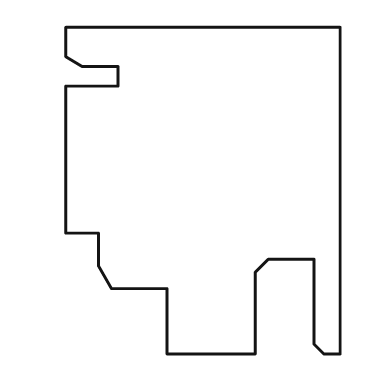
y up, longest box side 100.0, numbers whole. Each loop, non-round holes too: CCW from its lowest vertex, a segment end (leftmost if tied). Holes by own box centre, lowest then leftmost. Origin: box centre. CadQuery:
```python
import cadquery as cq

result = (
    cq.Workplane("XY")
    .moveTo(-11.0, -50.0)
    .lineTo(16.0, -50.0)
    .lineTo(16.0, -25.0)
    .lineTo(20.0, -21.0)
    .lineTo(34.0, -21.0)
    .lineTo(34.0, -47.0)
    .lineTo(37.0, -50.0)
    .lineTo(42.0, -50.0)
    .lineTo(42.0, 50.0)
    .lineTo(-42.0, 50.0)
    .lineTo(-42.0, 41.0)
    .lineTo(-37.0, 38.0)
    .lineTo(-26.0, 38.0)
    .lineTo(-26.0, 32.0)
    .lineTo(-42.0, 32.0)
    .lineTo(-42.0, -13.0)
    .lineTo(-32.0, -13.0)
    .lineTo(-32.0, -23.0)
    .lineTo(-28.0, -30.0)
    .lineTo(-11.0, -30.0)
    .close()
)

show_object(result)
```